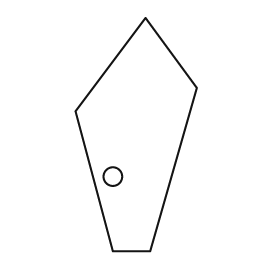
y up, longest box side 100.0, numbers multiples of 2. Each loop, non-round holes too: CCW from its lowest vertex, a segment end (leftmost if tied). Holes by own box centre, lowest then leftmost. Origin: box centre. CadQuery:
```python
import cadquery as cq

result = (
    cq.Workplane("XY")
    .moveTo(-10.0, -50.0)
    .lineTo(6.0, -50.0)
    .lineTo(26.0, 20.0)
    .lineTo(4.0, 50.0)
    .lineTo(-26.0, 10.0)
    .close()
    .moveTo(-10.0, -18.0)
    .circle(4.0)
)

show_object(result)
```